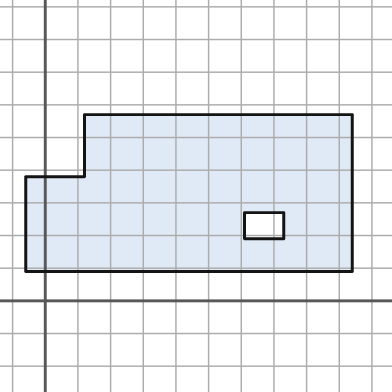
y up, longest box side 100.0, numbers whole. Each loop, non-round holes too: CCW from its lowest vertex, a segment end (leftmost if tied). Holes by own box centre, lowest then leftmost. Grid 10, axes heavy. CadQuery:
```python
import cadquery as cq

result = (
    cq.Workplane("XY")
    .moveTo(-6.0, 9.0)
    .lineTo(94.0, 9.0)
    .lineTo(94.0, 57.0)
    .lineTo(12.0, 57.0)
    .lineTo(12.0, 38.0)
    .lineTo(-6.0, 38.0)
    .close()
    .moveTo(61.0, 19.0)
    .lineTo(73.0, 19.0)
    .lineTo(73.0, 27.0)
    .lineTo(61.0, 27.0)
    .close()
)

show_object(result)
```